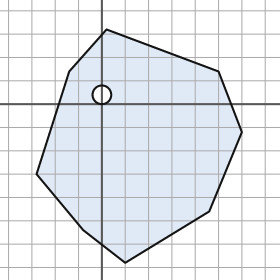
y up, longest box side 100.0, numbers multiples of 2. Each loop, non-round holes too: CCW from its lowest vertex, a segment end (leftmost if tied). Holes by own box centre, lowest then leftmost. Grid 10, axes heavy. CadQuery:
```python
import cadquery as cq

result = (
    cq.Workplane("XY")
    .moveTo(10.0, -68.0)
    .lineTo(46.0, -46.0)
    .lineTo(60.0, -12.0)
    .lineTo(50.0, 14.0)
    .lineTo(2.0, 32.0)
    .lineTo(-14.0, 14.0)
    .lineTo(-28.0, -30.0)
    .lineTo(-8.0, -54.0)
    .close()
    .moveTo(0.0, 4.0)
    .circle(4.0)
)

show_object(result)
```